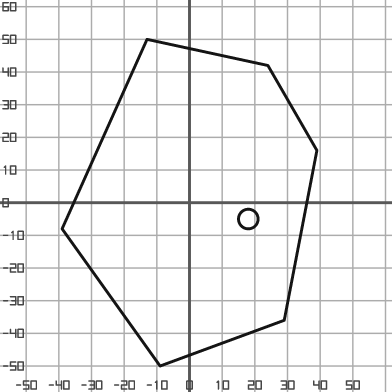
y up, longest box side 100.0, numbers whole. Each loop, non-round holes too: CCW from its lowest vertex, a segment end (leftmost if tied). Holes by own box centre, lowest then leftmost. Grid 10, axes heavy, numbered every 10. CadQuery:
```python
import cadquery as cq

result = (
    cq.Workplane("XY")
    .moveTo(-9.0, -50.0)
    .lineTo(29.0, -36.0)
    .lineTo(39.0, 16.0)
    .lineTo(24.0, 42.0)
    .lineTo(-13.0, 50.0)
    .lineTo(-39.0, -8.0)
    .close()
    .moveTo(18.0, -5.0)
    .circle(3.0)
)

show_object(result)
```